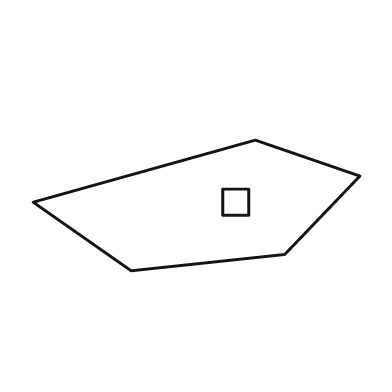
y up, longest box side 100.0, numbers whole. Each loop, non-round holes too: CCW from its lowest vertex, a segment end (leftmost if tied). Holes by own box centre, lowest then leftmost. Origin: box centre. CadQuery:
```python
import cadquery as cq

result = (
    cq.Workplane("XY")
    .moveTo(-20.0, -20.0)
    .lineTo(27.0, -15.0)
    .lineTo(50.0, 9.0)
    .lineTo(18.0, 20.0)
    .lineTo(-50.0, 1.0)
    .close()
    .moveTo(8.0, -3.0)
    .lineTo(16.0, -3.0)
    .lineTo(16.0, 5.0)
    .lineTo(8.0, 5.0)
    .close()
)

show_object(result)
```